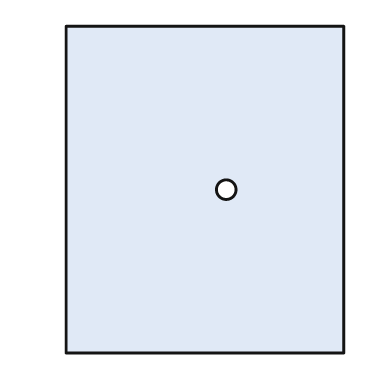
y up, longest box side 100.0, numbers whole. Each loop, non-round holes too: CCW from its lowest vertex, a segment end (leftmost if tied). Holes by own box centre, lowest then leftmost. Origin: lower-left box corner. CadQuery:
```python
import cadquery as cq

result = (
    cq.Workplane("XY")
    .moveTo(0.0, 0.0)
    .lineTo(85.0, 0.0)
    .lineTo(85.0, 100.0)
    .lineTo(0.0, 100.0)
    .close()
    .moveTo(49.0, 50.0)
    .circle(3.0)
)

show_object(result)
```